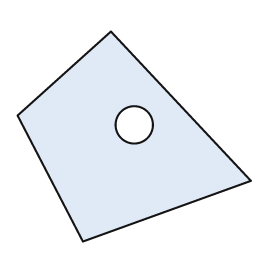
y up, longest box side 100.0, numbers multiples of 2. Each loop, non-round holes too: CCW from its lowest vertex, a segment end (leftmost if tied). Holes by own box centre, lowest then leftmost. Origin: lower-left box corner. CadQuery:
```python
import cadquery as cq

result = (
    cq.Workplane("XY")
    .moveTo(28.0, 0.0)
    .lineTo(100.0, 26.0)
    .lineTo(40.0, 90.0)
    .lineTo(0.0, 54.0)
    .close()
    .moveTo(50.0, 50.0)
    .circle(8.0)
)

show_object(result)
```